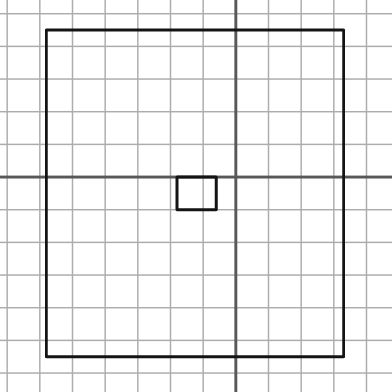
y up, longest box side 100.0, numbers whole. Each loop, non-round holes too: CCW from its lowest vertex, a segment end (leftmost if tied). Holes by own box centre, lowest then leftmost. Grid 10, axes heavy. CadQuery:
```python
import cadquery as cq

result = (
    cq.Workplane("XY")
    .moveTo(-58.0, -55.0)
    .lineTo(33.0, -55.0)
    .lineTo(33.0, 45.0)
    .lineTo(-58.0, 45.0)
    .close()
    .moveTo(-18.0, -10.0)
    .lineTo(-6.0, -10.0)
    .lineTo(-6.0, 0.0)
    .lineTo(-18.0, 0.0)
    .close()
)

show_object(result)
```